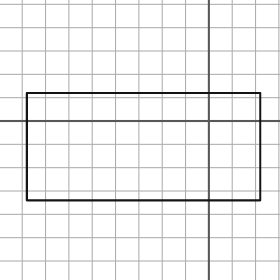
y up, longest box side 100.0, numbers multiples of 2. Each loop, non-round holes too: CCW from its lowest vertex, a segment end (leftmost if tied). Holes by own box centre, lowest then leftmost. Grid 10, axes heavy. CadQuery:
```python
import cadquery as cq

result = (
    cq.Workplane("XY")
    .moveTo(-78.0, -34.0)
    .lineTo(22.0, -34.0)
    .lineTo(22.0, 12.0)
    .lineTo(-78.0, 12.0)
    .close()
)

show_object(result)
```